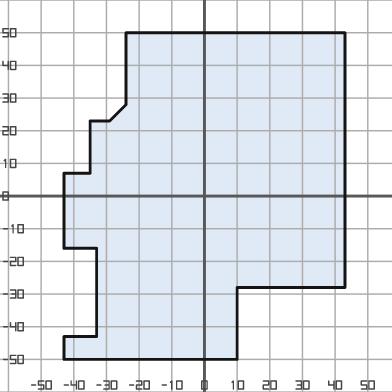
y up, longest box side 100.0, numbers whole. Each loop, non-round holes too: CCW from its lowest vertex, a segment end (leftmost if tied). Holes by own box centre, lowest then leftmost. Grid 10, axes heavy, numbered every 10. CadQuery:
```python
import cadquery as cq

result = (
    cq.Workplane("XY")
    .moveTo(-43.0, -50.0)
    .lineTo(10.0, -50.0)
    .lineTo(10.0, -28.0)
    .lineTo(43.0, -28.0)
    .lineTo(43.0, 50.0)
    .lineTo(-24.0, 50.0)
    .lineTo(-24.0, 28.0)
    .lineTo(-29.0, 23.0)
    .lineTo(-35.0, 23.0)
    .lineTo(-35.0, 7.0)
    .lineTo(-43.0, 7.0)
    .lineTo(-43.0, -16.0)
    .lineTo(-33.0, -16.0)
    .lineTo(-33.0, -43.0)
    .lineTo(-43.0, -43.0)
    .close()
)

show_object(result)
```